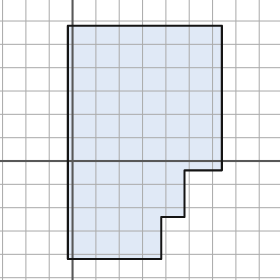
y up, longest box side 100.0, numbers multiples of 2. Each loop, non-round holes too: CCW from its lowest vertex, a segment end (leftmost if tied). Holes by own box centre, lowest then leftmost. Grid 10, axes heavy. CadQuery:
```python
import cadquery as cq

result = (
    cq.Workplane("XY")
    .moveTo(-2.0, -42.0)
    .lineTo(38.0, -42.0)
    .lineTo(38.0, -24.0)
    .lineTo(48.0, -24.0)
    .lineTo(48.0, -4.0)
    .lineTo(64.0, -4.0)
    .lineTo(64.0, 58.0)
    .lineTo(-2.0, 58.0)
    .close()
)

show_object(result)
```